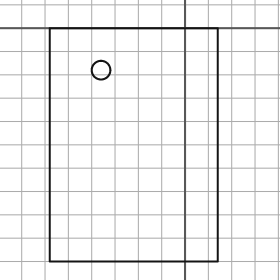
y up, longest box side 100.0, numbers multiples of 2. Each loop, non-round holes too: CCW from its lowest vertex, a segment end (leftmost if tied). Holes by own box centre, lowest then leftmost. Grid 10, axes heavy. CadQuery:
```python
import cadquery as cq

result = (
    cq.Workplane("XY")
    .moveTo(-58.0, -100.0)
    .lineTo(14.0, -100.0)
    .lineTo(14.0, 0.0)
    .lineTo(-58.0, 0.0)
    .close()
    .moveTo(-36.0, -18.0)
    .circle(4.0)
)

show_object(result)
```